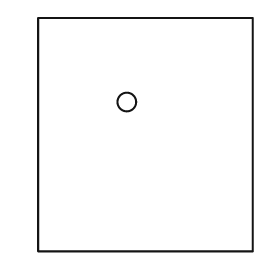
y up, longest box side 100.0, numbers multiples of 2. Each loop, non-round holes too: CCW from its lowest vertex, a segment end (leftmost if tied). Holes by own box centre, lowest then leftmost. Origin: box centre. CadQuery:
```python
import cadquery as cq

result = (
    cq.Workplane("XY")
    .moveTo(-46.0, -50.0)
    .lineTo(46.0, -50.0)
    .lineTo(46.0, 50.0)
    .lineTo(-46.0, 50.0)
    .close()
    .moveTo(-8.0, 14.0)
    .circle(4.0)
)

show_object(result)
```